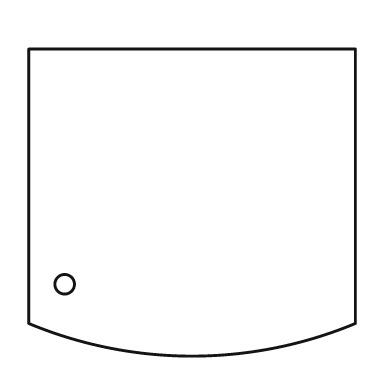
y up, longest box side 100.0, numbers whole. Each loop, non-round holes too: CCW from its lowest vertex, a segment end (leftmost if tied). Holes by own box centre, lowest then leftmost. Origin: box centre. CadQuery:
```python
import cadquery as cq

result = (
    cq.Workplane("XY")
    .moveTo(-50.0, -37.0)
    .threePointArc((0.0, -47.0), (50.0, -37.0))
    .lineTo(50.0, 47.0)
    .lineTo(-50.0, 47.0)
    .close()
    .moveTo(-39.0, -25.0)
    .circle(3.0)
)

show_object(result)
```